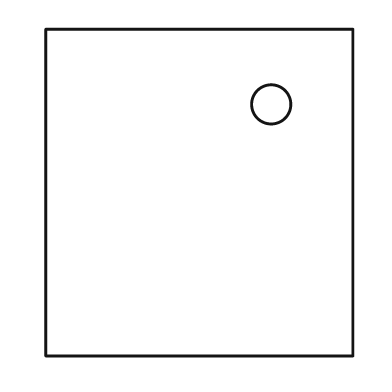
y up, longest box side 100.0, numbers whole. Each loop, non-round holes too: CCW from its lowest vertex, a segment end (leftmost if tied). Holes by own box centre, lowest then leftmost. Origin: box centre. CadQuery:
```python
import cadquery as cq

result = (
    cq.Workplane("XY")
    .moveTo(-47.0, -50.0)
    .lineTo(47.0, -50.0)
    .lineTo(47.0, 50.0)
    .lineTo(-47.0, 50.0)
    .close()
    .moveTo(22.0, 27.0)
    .circle(6.0)
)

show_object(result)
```